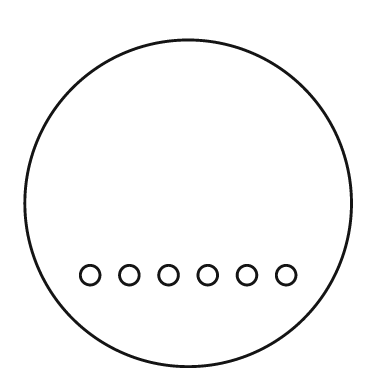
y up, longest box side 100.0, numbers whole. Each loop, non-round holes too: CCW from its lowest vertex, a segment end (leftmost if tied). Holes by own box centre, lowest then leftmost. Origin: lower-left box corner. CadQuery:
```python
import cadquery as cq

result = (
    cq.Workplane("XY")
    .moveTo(50.0, 50.0)
    .circle(50.0)
    .moveTo(20.0, 28.0)
    .circle(3.0)
    .moveTo(32.0, 28.0)
    .circle(3.0)
    .moveTo(44.0, 28.0)
    .circle(3.0)
    .moveTo(56.0, 28.0)
    .circle(3.0)
    .moveTo(68.0, 28.0)
    .circle(3.0)
    .moveTo(80.0, 28.0)
    .circle(3.0)
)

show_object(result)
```